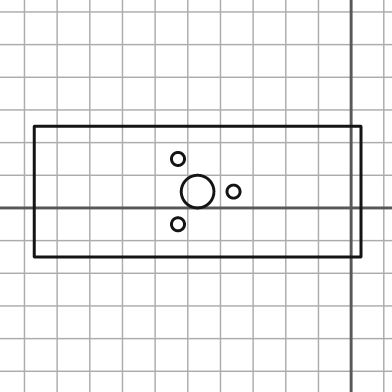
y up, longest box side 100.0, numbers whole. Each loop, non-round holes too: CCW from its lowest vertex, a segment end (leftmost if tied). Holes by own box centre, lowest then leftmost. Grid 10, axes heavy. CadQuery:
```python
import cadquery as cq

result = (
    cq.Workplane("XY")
    .moveTo(-97.0, -15.0)
    .lineTo(3.0, -15.0)
    .lineTo(3.0, 25.0)
    .lineTo(-97.0, 25.0)
    .close()
    .moveTo(-53.0, -5.0)
    .circle(2.0)
    .moveTo(-47.0, 5.0)
    .circle(5.0)
    .moveTo(-36.0, 5.0)
    .circle(2.0)
    .moveTo(-53.0, 15.0)
    .circle(2.0)
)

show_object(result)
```